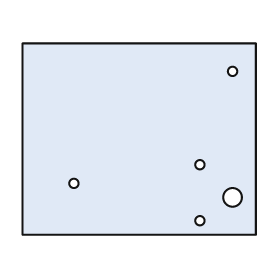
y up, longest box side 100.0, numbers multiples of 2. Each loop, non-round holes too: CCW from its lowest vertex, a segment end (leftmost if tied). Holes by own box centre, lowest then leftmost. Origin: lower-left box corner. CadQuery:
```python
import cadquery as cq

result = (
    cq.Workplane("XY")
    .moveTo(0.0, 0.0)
    .lineTo(100.0, 0.0)
    .lineTo(100.0, 82.0)
    .lineTo(0.0, 82.0)
    .close()
    .moveTo(76.0, 6.0)
    .circle(2.0)
    .moveTo(90.0, 16.0)
    .circle(4.0)
    .moveTo(22.0, 22.0)
    .circle(2.0)
    .moveTo(76.0, 30.0)
    .circle(2.0)
    .moveTo(90.0, 70.0)
    .circle(2.0)
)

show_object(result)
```